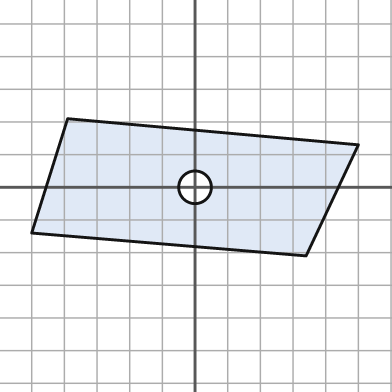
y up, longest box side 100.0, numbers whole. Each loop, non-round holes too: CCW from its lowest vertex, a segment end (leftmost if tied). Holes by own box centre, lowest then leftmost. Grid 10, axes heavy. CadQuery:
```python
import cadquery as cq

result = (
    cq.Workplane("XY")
    .moveTo(34.0, -21.0)
    .lineTo(50.0, 13.0)
    .lineTo(-39.0, 21.0)
    .lineTo(-50.0, -14.0)
    .close()
    .moveTo(0.0, 0.0)
    .circle(5.0)
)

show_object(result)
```